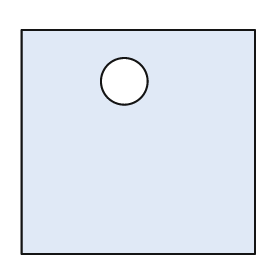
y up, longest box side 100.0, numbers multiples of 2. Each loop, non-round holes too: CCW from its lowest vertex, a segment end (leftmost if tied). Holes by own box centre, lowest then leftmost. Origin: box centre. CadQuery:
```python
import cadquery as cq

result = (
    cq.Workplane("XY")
    .moveTo(-50.0, -48.0)
    .lineTo(50.0, -48.0)
    .lineTo(50.0, 48.0)
    .lineTo(-50.0, 48.0)
    .close()
    .moveTo(-6.0, 26.0)
    .circle(10.0)
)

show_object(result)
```